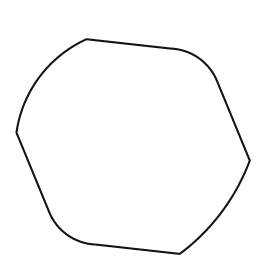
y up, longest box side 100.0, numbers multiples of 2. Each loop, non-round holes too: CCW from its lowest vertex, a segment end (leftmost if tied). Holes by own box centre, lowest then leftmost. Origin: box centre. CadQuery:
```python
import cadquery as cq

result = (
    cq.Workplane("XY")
    .moveTo(20.0, -46.0)
    .threePointArc((38.0, -28.0), (50.0, -6.0))
    .lineTo(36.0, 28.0)
    .threePointArc((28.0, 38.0), (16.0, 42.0))
    .lineTo(-20.0, 46.0)
    .threePointArc((-40.0, 30.0), (-50.0, 6.0))
    .lineTo(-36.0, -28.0)
    .threePointArc((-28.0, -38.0), (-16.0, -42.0))
    .close()
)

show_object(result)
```